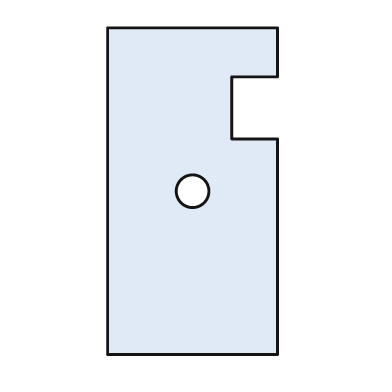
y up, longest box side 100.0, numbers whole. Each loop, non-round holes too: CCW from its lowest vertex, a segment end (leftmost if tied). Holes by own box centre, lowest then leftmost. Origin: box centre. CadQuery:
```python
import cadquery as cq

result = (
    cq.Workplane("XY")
    .moveTo(-26.0, -50.0)
    .lineTo(26.0, -50.0)
    .lineTo(26.0, 16.0)
    .lineTo(12.0, 16.0)
    .lineTo(12.0, 35.0)
    .lineTo(26.0, 35.0)
    .lineTo(26.0, 50.0)
    .lineTo(-26.0, 50.0)
    .close()
    .moveTo(0.0, 0.0)
    .circle(5.0)
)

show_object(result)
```